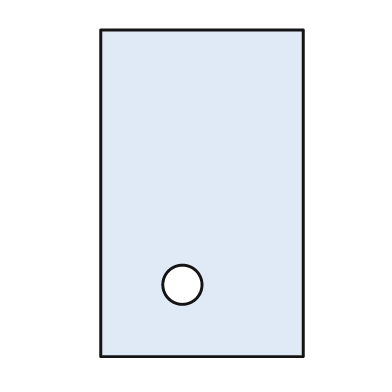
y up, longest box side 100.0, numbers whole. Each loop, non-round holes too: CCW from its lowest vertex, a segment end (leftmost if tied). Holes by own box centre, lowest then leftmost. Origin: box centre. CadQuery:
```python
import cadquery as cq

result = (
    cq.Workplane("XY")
    .moveTo(-31.0, -50.0)
    .lineTo(31.0, -50.0)
    .lineTo(31.0, 50.0)
    .lineTo(-31.0, 50.0)
    .close()
    .moveTo(-6.0, -28.0)
    .circle(6.0)
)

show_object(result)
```